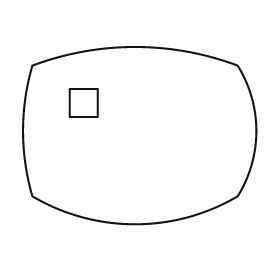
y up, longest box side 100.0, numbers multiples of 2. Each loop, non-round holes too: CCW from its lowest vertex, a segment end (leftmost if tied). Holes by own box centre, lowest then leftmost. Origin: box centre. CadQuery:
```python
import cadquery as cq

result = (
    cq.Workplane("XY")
    .moveTo(-46.0, -26.0)
    .threePointArc((-2.0, -38.0), (42.0, -26.0))
    .threePointArc((50.0, 2.0), (42.0, 30.0))
    .threePointArc((-2.0, 38.0), (-46.0, 30.0))
    .threePointArc((-50.0, 2.0), (-46.0, -26.0))
    .close()
    .moveTo(-30.0, 8.0)
    .lineTo(-18.0, 8.0)
    .lineTo(-18.0, 20.0)
    .lineTo(-30.0, 20.0)
    .close()
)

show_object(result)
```